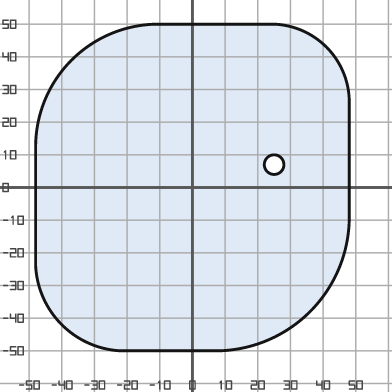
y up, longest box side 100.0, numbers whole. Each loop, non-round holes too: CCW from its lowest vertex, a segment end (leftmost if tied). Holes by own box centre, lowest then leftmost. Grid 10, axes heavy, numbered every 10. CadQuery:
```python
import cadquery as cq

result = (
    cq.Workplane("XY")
    .moveTo(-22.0, -50.0)
    .lineTo(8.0, -50.0)
    .threePointArc((36.0, -38.0), (48.0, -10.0))
    .lineTo(48.0, 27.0)
    .threePointArc((41.0, 43.0), (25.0, 50.0))
    .lineTo(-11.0, 50.0)
    .threePointArc((-37.0, 39.0), (-48.0, 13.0))
    .lineTo(-48.0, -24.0)
    .threePointArc((-40.0, -42.0), (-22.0, -50.0))
    .close()
    .moveTo(25.0, 7.0)
    .circle(3.0)
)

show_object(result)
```